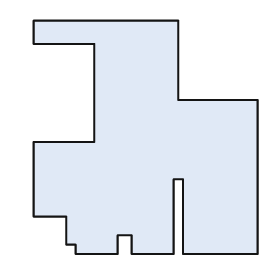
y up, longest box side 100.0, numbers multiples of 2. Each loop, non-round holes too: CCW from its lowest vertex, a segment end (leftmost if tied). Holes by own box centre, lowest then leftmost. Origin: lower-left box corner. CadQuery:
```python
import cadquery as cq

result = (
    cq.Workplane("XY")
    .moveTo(18.0, 0.0)
    .lineTo(36.0, 0.0)
    .lineTo(36.0, 8.0)
    .lineTo(42.0, 8.0)
    .lineTo(42.0, 0.0)
    .lineTo(60.0, 0.0)
    .lineTo(60.0, 32.0)
    .lineTo(64.0, 32.0)
    .lineTo(64.0, 0.0)
    .lineTo(96.0, 0.0)
    .lineTo(96.0, 66.0)
    .lineTo(62.0, 66.0)
    .lineTo(62.0, 100.0)
    .lineTo(0.0, 100.0)
    .lineTo(0.0, 90.0)
    .lineTo(26.0, 90.0)
    .lineTo(26.0, 48.0)
    .lineTo(0.0, 48.0)
    .lineTo(0.0, 16.0)
    .lineTo(14.0, 16.0)
    .lineTo(14.0, 4.0)
    .lineTo(18.0, 4.0)
    .close()
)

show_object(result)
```